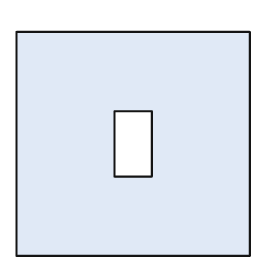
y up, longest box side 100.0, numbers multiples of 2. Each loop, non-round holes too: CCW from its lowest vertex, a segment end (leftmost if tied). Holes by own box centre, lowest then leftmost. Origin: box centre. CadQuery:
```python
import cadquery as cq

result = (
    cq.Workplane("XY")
    .moveTo(-50.0, -48.0)
    .lineTo(50.0, -48.0)
    .lineTo(50.0, 48.0)
    .lineTo(-50.0, 48.0)
    .close()
    .moveTo(-8.0, -14.0)
    .lineTo(8.0, -14.0)
    .lineTo(8.0, 14.0)
    .lineTo(-8.0, 14.0)
    .close()
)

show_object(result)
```